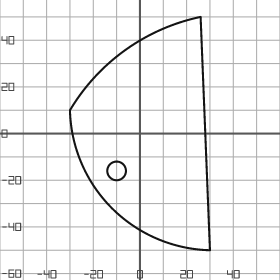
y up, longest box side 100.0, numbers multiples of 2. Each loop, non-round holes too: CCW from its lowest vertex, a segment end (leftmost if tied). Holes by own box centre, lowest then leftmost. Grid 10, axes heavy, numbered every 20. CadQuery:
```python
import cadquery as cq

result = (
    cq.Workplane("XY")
    .moveTo(30.0, -50.0)
    .lineTo(26.0, 50.0)
    .threePointArc((-6.0, 36.0), (-30.0, 10.0))
    .threePointArc((-12.0, -32.0), (30.0, -50.0))
    .close()
    .moveTo(-10.0, -16.0)
    .circle(4.0)
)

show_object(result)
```